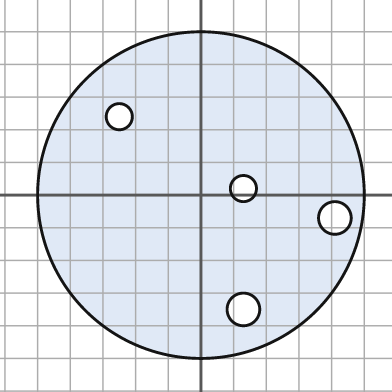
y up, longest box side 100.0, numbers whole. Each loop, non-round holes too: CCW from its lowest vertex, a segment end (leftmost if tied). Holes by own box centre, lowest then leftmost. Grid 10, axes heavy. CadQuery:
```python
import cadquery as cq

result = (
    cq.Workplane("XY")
    .moveTo(0.0, 0.0)
    .circle(50.0)
    .moveTo(13.0, -35.0)
    .circle(5.0)
    .moveTo(41.0, -7.0)
    .circle(5.0)
    .moveTo(13.0, 2.0)
    .circle(4.0)
    .moveTo(-25.0, 24.0)
    .circle(4.0)
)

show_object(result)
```